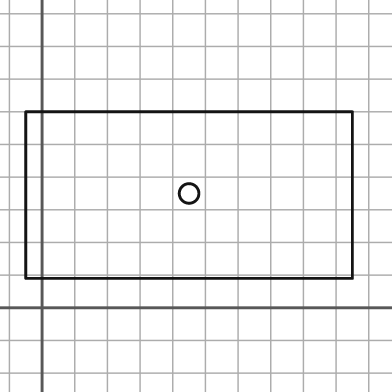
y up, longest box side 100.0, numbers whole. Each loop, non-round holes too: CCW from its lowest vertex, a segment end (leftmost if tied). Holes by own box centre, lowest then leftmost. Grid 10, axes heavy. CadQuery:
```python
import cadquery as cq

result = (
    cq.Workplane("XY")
    .moveTo(-5.0, 9.0)
    .lineTo(95.0, 9.0)
    .lineTo(95.0, 60.0)
    .lineTo(-5.0, 60.0)
    .close()
    .moveTo(45.0, 35.0)
    .circle(3.0)
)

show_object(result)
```